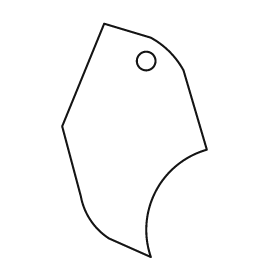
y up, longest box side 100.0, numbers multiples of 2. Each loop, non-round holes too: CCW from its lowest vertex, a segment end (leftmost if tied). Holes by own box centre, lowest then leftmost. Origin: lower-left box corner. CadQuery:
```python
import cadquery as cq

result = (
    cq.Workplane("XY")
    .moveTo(38.0, 0.0)
    .threePointArc((40.0, 28.0), (62.0, 46.0))
    .lineTo(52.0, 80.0)
    .threePointArc((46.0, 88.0), (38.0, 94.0))
    .lineTo(18.0, 100.0)
    .lineTo(0.0, 56.0)
    .lineTo(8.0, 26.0)
    .threePointArc((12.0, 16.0), (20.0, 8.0))
    .close()
    .moveTo(36.0, 84.0)
    .circle(4.0)
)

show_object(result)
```